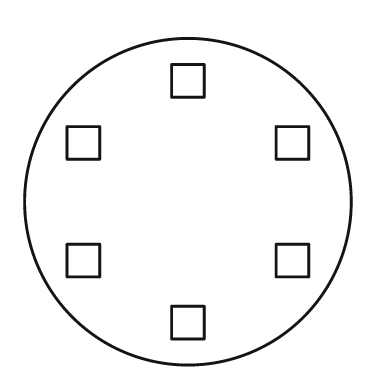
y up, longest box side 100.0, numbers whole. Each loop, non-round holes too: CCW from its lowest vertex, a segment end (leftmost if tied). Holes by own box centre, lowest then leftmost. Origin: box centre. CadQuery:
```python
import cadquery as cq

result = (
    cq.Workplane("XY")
    .moveTo(0.0, 0.0)
    .circle(50.0)
    .moveTo(-5.0, -42.0)
    .lineTo(5.0, -42.0)
    .lineTo(5.0, -32.0)
    .lineTo(-5.0, -32.0)
    .close()
    .moveTo(-37.0, -23.0)
    .lineTo(-27.0, -23.0)
    .lineTo(-27.0, -13.0)
    .lineTo(-37.0, -13.0)
    .close()
    .moveTo(27.0, -23.0)
    .lineTo(37.0, -23.0)
    .lineTo(37.0, -13.0)
    .lineTo(27.0, -13.0)
    .close()
    .moveTo(-37.0, 13.0)
    .lineTo(-27.0, 13.0)
    .lineTo(-27.0, 23.0)
    .lineTo(-37.0, 23.0)
    .close()
    .moveTo(27.0, 13.0)
    .lineTo(37.0, 13.0)
    .lineTo(37.0, 23.0)
    .lineTo(27.0, 23.0)
    .close()
    .moveTo(-5.0, 32.0)
    .lineTo(5.0, 32.0)
    .lineTo(5.0, 42.0)
    .lineTo(-5.0, 42.0)
    .close()
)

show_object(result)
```